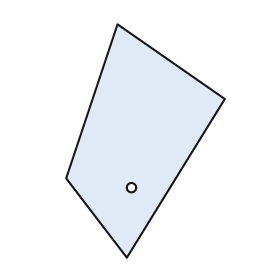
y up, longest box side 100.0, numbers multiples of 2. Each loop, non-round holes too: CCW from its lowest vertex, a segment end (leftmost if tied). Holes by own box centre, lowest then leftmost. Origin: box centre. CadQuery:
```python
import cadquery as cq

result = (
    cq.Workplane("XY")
    .moveTo(-8.0, -50.0)
    .lineTo(34.0, 18.0)
    .lineTo(-12.0, 50.0)
    .lineTo(-34.0, -16.0)
    .close()
    .moveTo(-6.0, -20.0)
    .circle(2.0)
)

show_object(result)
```